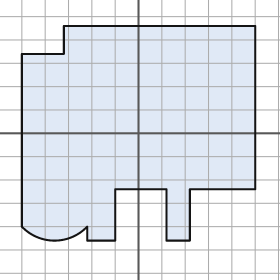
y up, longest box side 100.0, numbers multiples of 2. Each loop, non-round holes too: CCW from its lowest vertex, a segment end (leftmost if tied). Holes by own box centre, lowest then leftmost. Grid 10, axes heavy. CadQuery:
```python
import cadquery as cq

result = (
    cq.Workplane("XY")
    .moveTo(-22.0, -46.0)
    .lineTo(-10.0, -46.0)
    .lineTo(-10.0, -24.0)
    .lineTo(12.0, -24.0)
    .lineTo(12.0, -46.0)
    .lineTo(22.0, -46.0)
    .lineTo(22.0, -24.0)
    .lineTo(50.0, -24.0)
    .lineTo(50.0, 46.0)
    .lineTo(-32.0, 46.0)
    .lineTo(-32.0, 34.0)
    .lineTo(-50.0, 34.0)
    .lineTo(-50.0, -40.0)
    .threePointArc((-36.0, -46.0), (-22.0, -40.0))
    .close()
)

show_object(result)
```